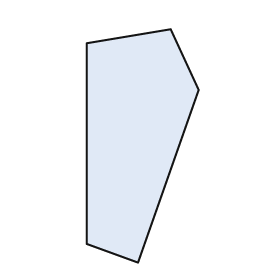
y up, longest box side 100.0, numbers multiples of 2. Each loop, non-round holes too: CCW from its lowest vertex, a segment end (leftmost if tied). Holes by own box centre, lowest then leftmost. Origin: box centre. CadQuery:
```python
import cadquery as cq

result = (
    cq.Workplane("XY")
    .moveTo(-2.0, -50.0)
    .lineTo(24.0, 24.0)
    .lineTo(12.0, 50.0)
    .lineTo(-24.0, 44.0)
    .lineTo(-24.0, -42.0)
    .close()
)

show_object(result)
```